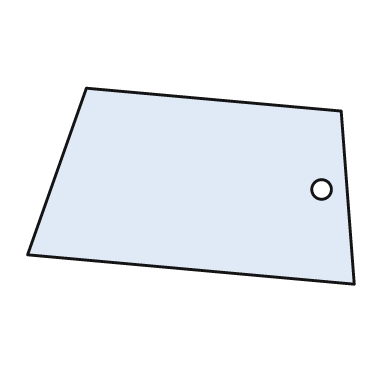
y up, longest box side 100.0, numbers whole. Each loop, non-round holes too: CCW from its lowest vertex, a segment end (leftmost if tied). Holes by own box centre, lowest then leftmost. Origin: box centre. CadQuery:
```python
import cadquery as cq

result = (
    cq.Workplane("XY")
    .moveTo(50.0, -30.0)
    .lineTo(46.0, 23.0)
    .lineTo(-32.0, 30.0)
    .lineTo(-50.0, -21.0)
    .close()
    .moveTo(40.0, -1.0)
    .circle(3.0)
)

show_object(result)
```